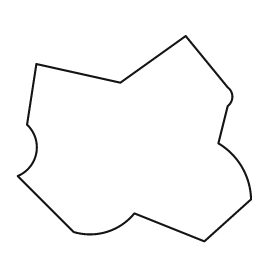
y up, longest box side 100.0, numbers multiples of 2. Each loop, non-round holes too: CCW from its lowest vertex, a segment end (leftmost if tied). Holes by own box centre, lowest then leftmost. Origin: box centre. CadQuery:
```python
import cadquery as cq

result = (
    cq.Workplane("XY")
    .moveTo(30.0, -44.0)
    .lineTo(50.0, -26.0)
    .threePointArc((46.0, -12.0), (36.0, -2.0))
    .lineTo(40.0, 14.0)
    .threePointArc((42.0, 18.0), (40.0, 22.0))
    .lineTo(22.0, 44.0)
    .lineTo(-6.0, 24.0)
    .lineTo(-42.0, 32.0)
    .lineTo(-46.0, 6.0)
    .threePointArc((-42.0, -6.0), (-50.0, -16.0))
    .lineTo(-26.0, -40.0)
    .threePointArc((-12.0, -40.0), (0.0, -32.0))
    .close()
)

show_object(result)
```